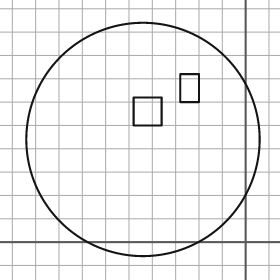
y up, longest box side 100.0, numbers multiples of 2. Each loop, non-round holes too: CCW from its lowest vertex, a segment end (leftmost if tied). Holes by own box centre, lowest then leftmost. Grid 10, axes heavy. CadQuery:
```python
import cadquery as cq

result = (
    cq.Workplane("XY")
    .moveTo(-44.0, 44.0)
    .circle(50.0)
    .moveTo(-48.0, 50.0)
    .lineTo(-36.0, 50.0)
    .lineTo(-36.0, 62.0)
    .lineTo(-48.0, 62.0)
    .close()
    .moveTo(-28.0, 60.0)
    .lineTo(-20.0, 60.0)
    .lineTo(-20.0, 72.0)
    .lineTo(-28.0, 72.0)
    .close()
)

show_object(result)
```